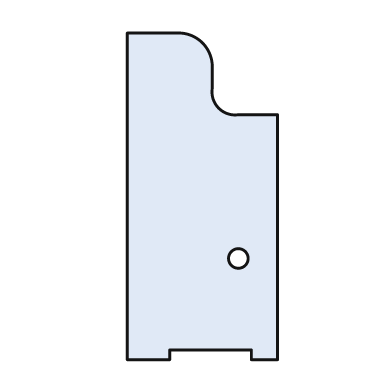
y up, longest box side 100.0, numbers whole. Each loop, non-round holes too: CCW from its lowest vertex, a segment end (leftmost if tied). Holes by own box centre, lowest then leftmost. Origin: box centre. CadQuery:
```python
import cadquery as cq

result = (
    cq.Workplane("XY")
    .moveTo(-23.0, -50.0)
    .lineTo(-10.0, -50.0)
    .lineTo(-10.0, -47.0)
    .lineTo(15.0, -47.0)
    .lineTo(15.0, -50.0)
    .lineTo(23.0, -50.0)
    .lineTo(23.0, 25.0)
    .lineTo(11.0, 25.0)
    .threePointArc((5.0, 27.0), (3.0, 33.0))
    .lineTo(3.0, 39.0)
    .threePointArc((0.0, 47.0), (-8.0, 50.0))
    .lineTo(-23.0, 50.0)
    .close()
    .moveTo(11.0, -19.0)
    .circle(3.0)
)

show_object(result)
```